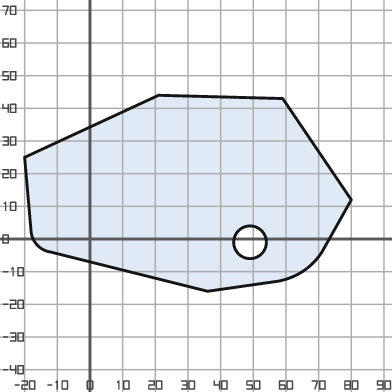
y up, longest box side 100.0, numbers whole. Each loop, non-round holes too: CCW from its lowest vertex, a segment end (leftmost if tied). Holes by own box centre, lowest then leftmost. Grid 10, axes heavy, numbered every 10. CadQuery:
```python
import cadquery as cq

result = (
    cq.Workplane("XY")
    .moveTo(36.0, -16.0)
    .lineTo(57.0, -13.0)
    .threePointArc((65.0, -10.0), (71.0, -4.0))
    .lineTo(80.0, 12.0)
    .lineTo(59.0, 43.0)
    .lineTo(21.0, 44.0)
    .lineTo(-20.0, 25.0)
    .lineTo(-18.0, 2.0)
    .threePointArc((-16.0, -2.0), (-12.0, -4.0))
    .close()
    .moveTo(49.0, -1.0)
    .circle(5.0)
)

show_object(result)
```